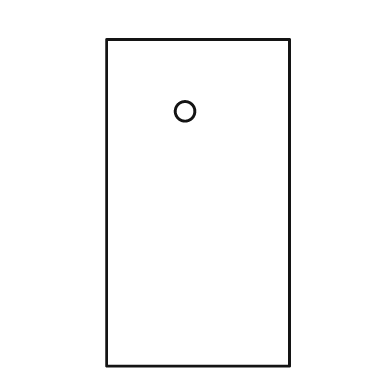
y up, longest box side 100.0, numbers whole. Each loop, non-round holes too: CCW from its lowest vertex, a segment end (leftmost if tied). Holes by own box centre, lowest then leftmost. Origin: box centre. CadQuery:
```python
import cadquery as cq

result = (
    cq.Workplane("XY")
    .moveTo(-28.0, -50.0)
    .lineTo(28.0, -50.0)
    .lineTo(28.0, 50.0)
    .lineTo(-28.0, 50.0)
    .close()
    .moveTo(-4.0, 28.0)
    .circle(3.0)
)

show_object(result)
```